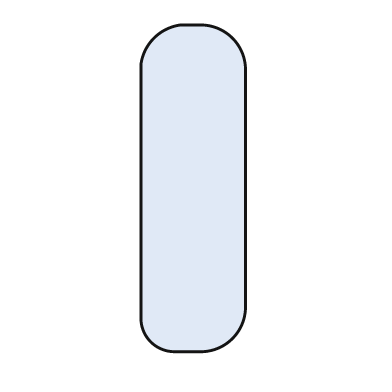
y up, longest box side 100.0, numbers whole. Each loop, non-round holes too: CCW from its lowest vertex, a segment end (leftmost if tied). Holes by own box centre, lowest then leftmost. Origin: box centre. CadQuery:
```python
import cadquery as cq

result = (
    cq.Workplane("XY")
    .moveTo(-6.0, -50.0)
    .lineTo(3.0, -50.0)
    .threePointArc((12.0, -46.0), (16.0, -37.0))
    .lineTo(16.0, 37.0)
    .threePointArc((12.0, 46.0), (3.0, 50.0))
    .lineTo(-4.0, 50.0)
    .threePointArc((-12.0, 46.0), (-16.0, 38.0))
    .lineTo(-16.0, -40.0)
    .threePointArc((-13.0, -47.0), (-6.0, -50.0))
    .close()
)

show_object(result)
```